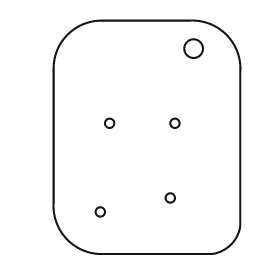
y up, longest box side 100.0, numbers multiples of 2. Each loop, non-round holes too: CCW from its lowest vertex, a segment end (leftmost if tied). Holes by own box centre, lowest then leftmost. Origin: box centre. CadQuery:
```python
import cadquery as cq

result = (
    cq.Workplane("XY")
    .moveTo(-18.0, -50.0)
    .lineTo(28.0, -50.0)
    .threePointArc((36.0, -46.0), (40.0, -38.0))
    .lineTo(40.0, 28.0)
    .threePointArc((34.0, 44.0), (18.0, 50.0))
    .lineTo(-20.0, 50.0)
    .threePointArc((-34.0, 44.0), (-40.0, 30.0))
    .lineTo(-40.0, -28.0)
    .threePointArc((-34.0, -44.0), (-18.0, -50.0))
    .close()
    .moveTo(-20.0, -32.0)
    .circle(2.0)
    .moveTo(10.0, -26.0)
    .circle(2.0)
    .moveTo(-16.0, 6.0)
    .circle(2.0)
    .moveTo(12.0, 6.0)
    .circle(2.0)
    .moveTo(20.0, 38.0)
    .circle(4.0)
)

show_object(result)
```